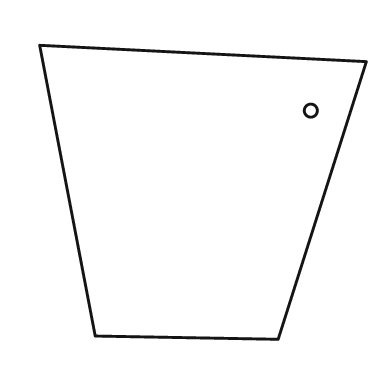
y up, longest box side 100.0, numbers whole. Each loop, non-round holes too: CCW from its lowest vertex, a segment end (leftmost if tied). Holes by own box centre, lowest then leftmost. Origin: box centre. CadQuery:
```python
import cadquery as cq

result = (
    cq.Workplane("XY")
    .moveTo(23.0, -45.0)
    .lineTo(50.0, 40.0)
    .lineTo(-50.0, 45.0)
    .lineTo(-33.0, -44.0)
    .close()
    .moveTo(33.0, 25.0)
    .circle(2.0)
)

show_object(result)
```